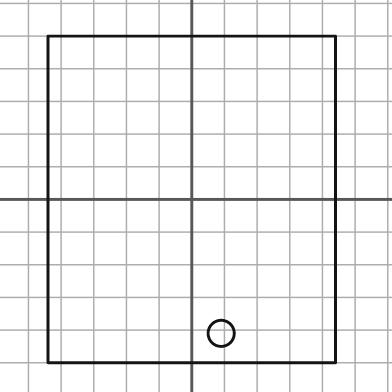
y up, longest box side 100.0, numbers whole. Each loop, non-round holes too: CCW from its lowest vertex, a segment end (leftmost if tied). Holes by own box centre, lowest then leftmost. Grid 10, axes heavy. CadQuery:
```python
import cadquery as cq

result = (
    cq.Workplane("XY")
    .moveTo(-44.0, -50.0)
    .lineTo(44.0, -50.0)
    .lineTo(44.0, 50.0)
    .lineTo(-44.0, 50.0)
    .close()
    .moveTo(9.0, -41.0)
    .circle(4.0)
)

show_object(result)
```